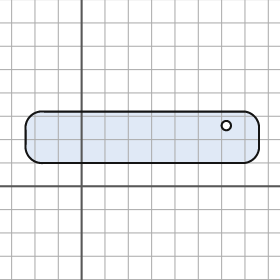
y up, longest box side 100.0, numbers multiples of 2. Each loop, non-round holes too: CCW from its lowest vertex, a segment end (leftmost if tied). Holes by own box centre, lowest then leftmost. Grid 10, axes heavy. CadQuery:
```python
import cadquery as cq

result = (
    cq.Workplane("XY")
    .moveTo(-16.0, 10.0)
    .lineTo(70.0, 10.0)
    .threePointArc((74.0, 12.0), (76.0, 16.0))
    .lineTo(76.0, 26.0)
    .threePointArc((74.0, 30.0), (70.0, 32.0))
    .lineTo(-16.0, 32.0)
    .threePointArc((-22.0, 30.0), (-24.0, 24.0))
    .lineTo(-24.0, 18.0)
    .threePointArc((-22.0, 12.0), (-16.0, 10.0))
    .close()
    .moveTo(62.0, 26.0)
    .circle(2.0)
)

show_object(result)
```